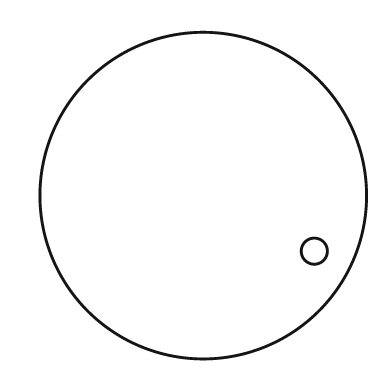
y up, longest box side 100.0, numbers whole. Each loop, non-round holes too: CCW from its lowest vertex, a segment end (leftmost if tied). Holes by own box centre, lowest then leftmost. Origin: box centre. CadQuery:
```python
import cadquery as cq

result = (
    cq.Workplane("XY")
    .moveTo(0.0, 0.0)
    .circle(50.0)
    .moveTo(34.0, -17.0)
    .circle(4.0)
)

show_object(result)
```